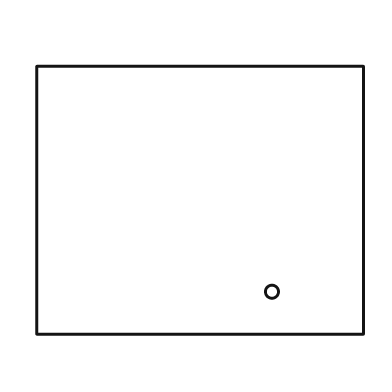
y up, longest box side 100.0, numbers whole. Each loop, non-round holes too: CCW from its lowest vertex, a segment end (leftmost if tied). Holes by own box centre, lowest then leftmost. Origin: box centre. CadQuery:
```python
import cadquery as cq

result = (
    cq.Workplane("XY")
    .moveTo(-50.0, -41.0)
    .lineTo(50.0, -41.0)
    .lineTo(50.0, 41.0)
    .lineTo(-50.0, 41.0)
    .close()
    .moveTo(22.0, -28.0)
    .circle(2.0)
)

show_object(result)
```